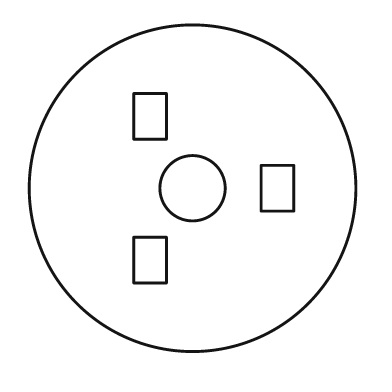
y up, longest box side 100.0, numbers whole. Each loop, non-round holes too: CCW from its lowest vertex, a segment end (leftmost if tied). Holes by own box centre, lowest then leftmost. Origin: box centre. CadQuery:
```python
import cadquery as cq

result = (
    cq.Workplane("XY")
    .moveTo(0.0, 0.0)
    .circle(50.0)
    .moveTo(-18.0, -29.0)
    .lineTo(-8.0, -29.0)
    .lineTo(-8.0, -15.0)
    .lineTo(-18.0, -15.0)
    .close()
    .moveTo(0.0, 0.0)
    .circle(10.0)
    .moveTo(21.0, -7.0)
    .lineTo(31.0, -7.0)
    .lineTo(31.0, 7.0)
    .lineTo(21.0, 7.0)
    .close()
    .moveTo(-18.0, 15.0)
    .lineTo(-8.0, 15.0)
    .lineTo(-8.0, 29.0)
    .lineTo(-18.0, 29.0)
    .close()
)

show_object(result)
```